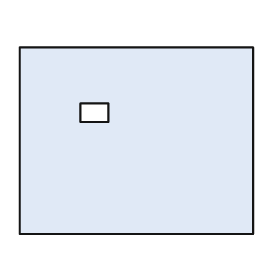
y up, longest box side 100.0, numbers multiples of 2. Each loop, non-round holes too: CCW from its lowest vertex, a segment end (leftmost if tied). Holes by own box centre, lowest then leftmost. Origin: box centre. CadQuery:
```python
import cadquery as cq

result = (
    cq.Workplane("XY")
    .moveTo(-50.0, -40.0)
    .lineTo(50.0, -40.0)
    .lineTo(50.0, 40.0)
    .lineTo(-50.0, 40.0)
    .close()
    .moveTo(-24.0, 8.0)
    .lineTo(-12.0, 8.0)
    .lineTo(-12.0, 16.0)
    .lineTo(-24.0, 16.0)
    .close()
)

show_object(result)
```